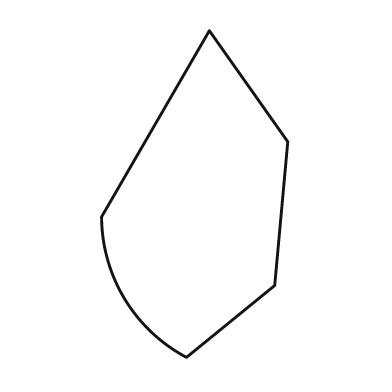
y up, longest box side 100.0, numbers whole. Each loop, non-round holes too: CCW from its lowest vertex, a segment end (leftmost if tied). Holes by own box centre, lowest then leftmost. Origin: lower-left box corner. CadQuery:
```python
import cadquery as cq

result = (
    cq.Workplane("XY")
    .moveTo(26.0, 0.0)
    .lineTo(53.0, 22.0)
    .lineTo(57.0, 66.0)
    .lineTo(33.0, 100.0)
    .lineTo(0.0, 43.0)
    .threePointArc((7.0, 18.0), (26.0, 0.0))
    .close()
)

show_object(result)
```